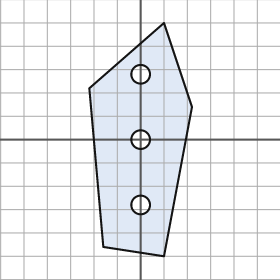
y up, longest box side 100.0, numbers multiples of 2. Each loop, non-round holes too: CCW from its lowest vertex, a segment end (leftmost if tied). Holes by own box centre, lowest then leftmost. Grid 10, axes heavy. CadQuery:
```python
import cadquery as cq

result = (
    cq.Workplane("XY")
    .moveTo(10.0, -50.0)
    .lineTo(22.0, 14.0)
    .lineTo(10.0, 50.0)
    .lineTo(-22.0, 22.0)
    .lineTo(-16.0, -46.0)
    .close()
    .moveTo(0.0, -28.0)
    .circle(4.0)
    .moveTo(0.0, 0.0)
    .circle(4.0)
    .moveTo(0.0, 28.0)
    .circle(4.0)
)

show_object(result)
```